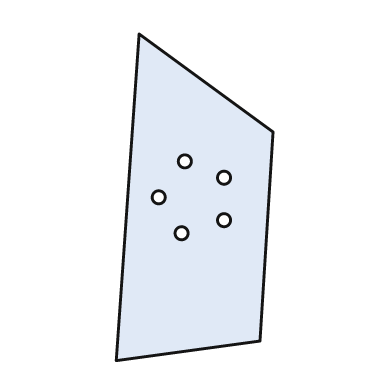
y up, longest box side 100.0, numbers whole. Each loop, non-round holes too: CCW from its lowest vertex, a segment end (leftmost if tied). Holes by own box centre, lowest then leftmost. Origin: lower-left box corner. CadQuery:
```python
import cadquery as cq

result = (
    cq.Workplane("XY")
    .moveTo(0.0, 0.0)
    .lineTo(44.0, 6.0)
    .lineTo(48.0, 70.0)
    .lineTo(7.0, 100.0)
    .close()
    .moveTo(20.0, 39.0)
    .circle(2.0)
    .moveTo(33.0, 43.0)
    .circle(2.0)
    .moveTo(13.0, 50.0)
    .circle(2.0)
    .moveTo(33.0, 56.0)
    .circle(2.0)
    .moveTo(21.0, 61.0)
    .circle(2.0)
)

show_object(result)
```